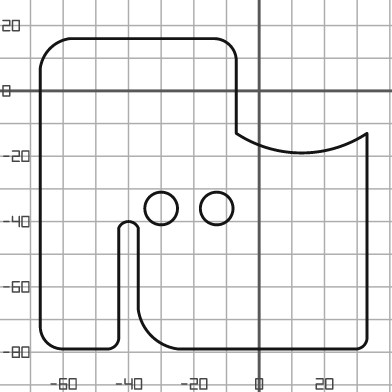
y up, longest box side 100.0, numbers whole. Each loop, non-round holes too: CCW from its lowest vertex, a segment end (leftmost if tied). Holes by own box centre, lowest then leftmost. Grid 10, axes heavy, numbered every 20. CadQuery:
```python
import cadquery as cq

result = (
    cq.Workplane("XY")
    .moveTo(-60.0, -79.0)
    .lineTo(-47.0, -79.0)
    .threePointArc((-44.0, -78.0), (-43.0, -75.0))
    .lineTo(-43.0, -42.0)
    .threePointArc((-40.0, -40.0), (-37.0, -42.0))
    .lineTo(-37.0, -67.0)
    .threePointArc((-33.0, -75.0), (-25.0, -79.0))
    .lineTo(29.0, -79.0)
    .threePointArc((32.0, -78.0), (33.0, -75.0))
    .lineTo(33.0, -13.0)
    .threePointArc((13.0, -19.0), (-7.0, -13.0))
    .lineTo(-7.0, 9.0)
    .threePointArc((-9.0, 14.0), (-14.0, 16.0))
    .lineTo(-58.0, 16.0)
    .threePointArc((-64.0, 13.0), (-67.0, 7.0))
    .lineTo(-67.0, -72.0)
    .threePointArc((-65.0, -77.0), (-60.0, -79.0))
    .close()
    .moveTo(-30.0, -36.0)
    .circle(5.0)
    .moveTo(-13.0, -36.0)
    .circle(5.0)
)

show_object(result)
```